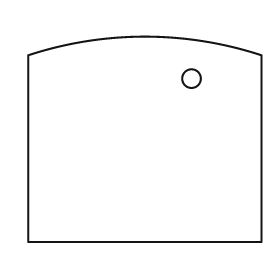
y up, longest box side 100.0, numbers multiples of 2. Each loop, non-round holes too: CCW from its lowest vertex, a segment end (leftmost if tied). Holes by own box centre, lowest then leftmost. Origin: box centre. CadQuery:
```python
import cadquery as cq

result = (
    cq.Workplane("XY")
    .moveTo(-50.0, -44.0)
    .lineTo(50.0, -44.0)
    .lineTo(50.0, 36.0)
    .threePointArc((0.0, 44.0), (-50.0, 36.0))
    .close()
    .moveTo(20.0, 26.0)
    .circle(4.0)
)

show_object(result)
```